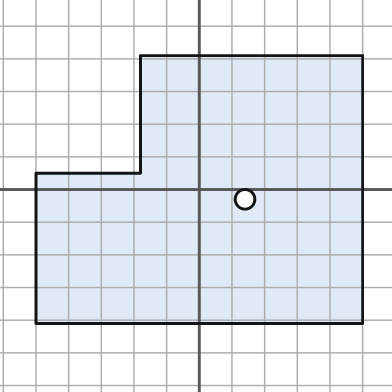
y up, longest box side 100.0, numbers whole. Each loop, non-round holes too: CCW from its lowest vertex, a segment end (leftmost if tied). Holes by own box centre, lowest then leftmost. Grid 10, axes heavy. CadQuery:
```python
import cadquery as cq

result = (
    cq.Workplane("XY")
    .moveTo(-50.0, -41.0)
    .lineTo(50.0, -41.0)
    .lineTo(50.0, 41.0)
    .lineTo(-18.0, 41.0)
    .lineTo(-18.0, 5.0)
    .lineTo(-50.0, 5.0)
    .close()
    .moveTo(14.0, -3.0)
    .circle(3.0)
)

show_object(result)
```